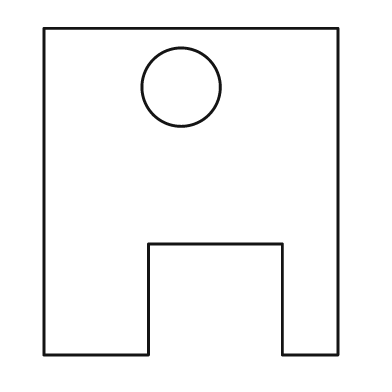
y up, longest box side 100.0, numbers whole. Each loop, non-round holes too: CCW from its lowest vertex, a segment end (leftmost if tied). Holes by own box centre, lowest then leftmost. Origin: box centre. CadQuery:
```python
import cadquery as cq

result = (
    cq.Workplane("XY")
    .moveTo(-45.0, -50.0)
    .lineTo(-13.0, -50.0)
    .lineTo(-13.0, -16.0)
    .lineTo(28.0, -16.0)
    .lineTo(28.0, -50.0)
    .lineTo(45.0, -50.0)
    .lineTo(45.0, 50.0)
    .lineTo(-45.0, 50.0)
    .close()
    .moveTo(-3.0, 32.0)
    .circle(12.0)
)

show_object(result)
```